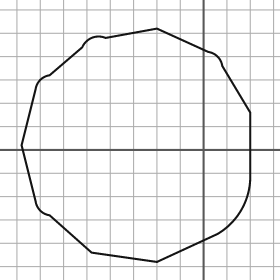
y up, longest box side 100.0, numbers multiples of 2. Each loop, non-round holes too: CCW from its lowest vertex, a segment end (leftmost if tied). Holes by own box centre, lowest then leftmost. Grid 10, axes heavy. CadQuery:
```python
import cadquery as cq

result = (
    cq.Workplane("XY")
    .moveTo(-20.0, -48.0)
    .lineTo(6.0, -36.0)
    .threePointArc((16.0, -26.0), (20.0, -12.0))
    .lineTo(20.0, 16.0)
    .lineTo(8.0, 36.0)
    .threePointArc((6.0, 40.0), (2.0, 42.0))
    .lineTo(-20.0, 52.0)
    .lineTo(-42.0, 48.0)
    .threePointArc((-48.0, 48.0), (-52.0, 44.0))
    .lineTo(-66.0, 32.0)
    .threePointArc((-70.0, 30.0), (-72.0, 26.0))
    .lineTo(-78.0, 2.0)
    .lineTo(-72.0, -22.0)
    .threePointArc((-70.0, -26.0), (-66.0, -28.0))
    .lineTo(-48.0, -44.0)
    .close()
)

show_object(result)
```